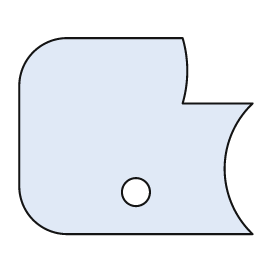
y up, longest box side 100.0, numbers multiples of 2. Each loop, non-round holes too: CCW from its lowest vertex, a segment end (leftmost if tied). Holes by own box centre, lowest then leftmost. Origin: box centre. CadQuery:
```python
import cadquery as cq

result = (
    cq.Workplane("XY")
    .moveTo(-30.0, -42.0)
    .lineTo(50.0, -42.0)
    .threePointArc((38.0, -14.0), (50.0, 14.0))
    .lineTo(20.0, 14.0)
    .threePointArc((22.0, 28.0), (20.0, 42.0))
    .lineTo(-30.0, 42.0)
    .threePointArc((-44.0, 36.0), (-50.0, 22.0))
    .lineTo(-50.0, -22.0)
    .threePointArc((-44.0, -36.0), (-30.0, -42.0))
    .close()
    .moveTo(0.0, -24.0)
    .circle(6.0)
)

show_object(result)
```